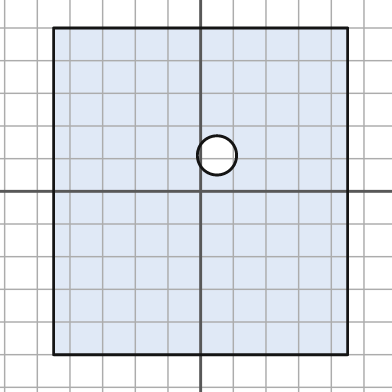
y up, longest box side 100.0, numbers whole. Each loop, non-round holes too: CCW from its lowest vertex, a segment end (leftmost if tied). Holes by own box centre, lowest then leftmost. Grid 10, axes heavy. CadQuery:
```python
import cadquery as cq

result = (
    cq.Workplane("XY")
    .moveTo(-45.0, -50.0)
    .lineTo(45.0, -50.0)
    .lineTo(45.0, 50.0)
    .lineTo(-45.0, 50.0)
    .close()
    .moveTo(5.0, 11.0)
    .circle(6.0)
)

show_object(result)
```